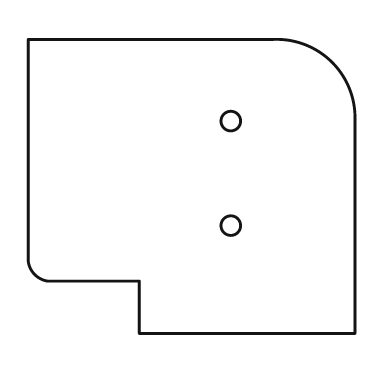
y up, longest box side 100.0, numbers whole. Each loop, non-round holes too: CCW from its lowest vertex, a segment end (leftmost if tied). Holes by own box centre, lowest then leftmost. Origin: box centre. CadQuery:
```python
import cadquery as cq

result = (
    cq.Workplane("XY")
    .moveTo(-16.0, -45.0)
    .lineTo(50.0, -45.0)
    .lineTo(50.0, 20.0)
    .threePointArc((43.0, 38.0), (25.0, 45.0))
    .lineTo(-50.0, 45.0)
    .lineTo(-50.0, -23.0)
    .threePointArc((-48.0, -27.0), (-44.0, -29.0))
    .lineTo(-16.0, -29.0)
    .close()
    .moveTo(12.0, -12.0)
    .circle(3.0)
    .moveTo(12.0, 20.0)
    .circle(3.0)
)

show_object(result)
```